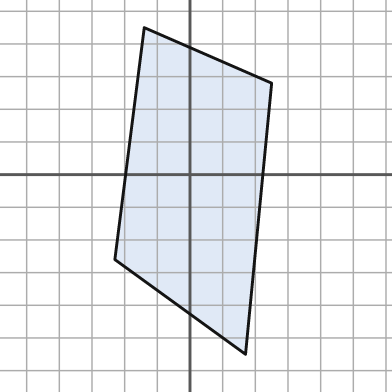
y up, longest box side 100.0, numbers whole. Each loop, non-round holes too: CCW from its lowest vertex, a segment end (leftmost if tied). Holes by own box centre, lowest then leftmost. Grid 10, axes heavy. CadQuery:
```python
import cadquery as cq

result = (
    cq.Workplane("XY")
    .moveTo(17.0, -55.0)
    .lineTo(25.0, 28.0)
    .lineTo(-14.0, 45.0)
    .lineTo(-23.0, -26.0)
    .close()
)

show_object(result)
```